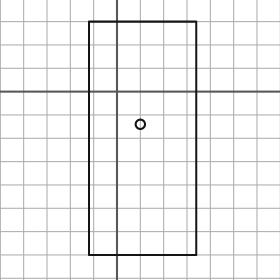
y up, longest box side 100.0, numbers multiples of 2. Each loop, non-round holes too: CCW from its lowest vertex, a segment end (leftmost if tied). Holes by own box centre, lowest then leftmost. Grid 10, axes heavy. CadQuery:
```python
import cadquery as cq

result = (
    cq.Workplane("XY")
    .moveTo(-12.0, -70.0)
    .lineTo(34.0, -70.0)
    .lineTo(34.0, 30.0)
    .lineTo(-12.0, 30.0)
    .close()
    .moveTo(10.0, -14.0)
    .circle(2.0)
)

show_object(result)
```